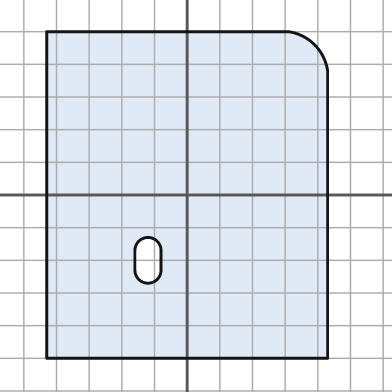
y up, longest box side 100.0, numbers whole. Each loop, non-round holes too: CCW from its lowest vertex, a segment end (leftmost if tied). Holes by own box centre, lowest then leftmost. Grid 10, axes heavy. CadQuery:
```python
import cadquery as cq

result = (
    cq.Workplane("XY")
    .moveTo(-43.0, -50.0)
    .lineTo(43.0, -50.0)
    .lineTo(43.0, 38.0)
    .threePointArc((39.0, 46.0), (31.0, 50.0))
    .lineTo(-43.0, 50.0)
    .close()
    .moveTo(-16.0, -23.0)
    .threePointArc((-12.0, -27.0), (-8.0, -23.0))
    .lineTo(-8.0, -17.0)
    .threePointArc((-12.0, -13.0), (-16.0, -17.0))
    .close()
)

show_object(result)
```